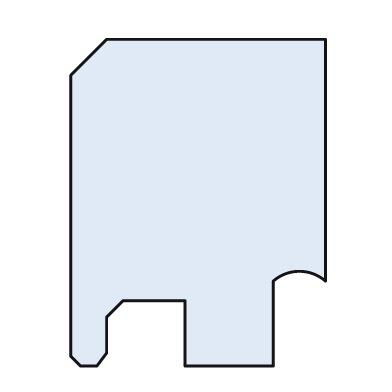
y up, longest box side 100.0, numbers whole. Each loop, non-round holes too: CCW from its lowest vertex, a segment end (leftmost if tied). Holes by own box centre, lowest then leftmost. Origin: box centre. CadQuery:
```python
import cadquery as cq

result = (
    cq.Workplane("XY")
    .moveTo(-36.0, -50.0)
    .lineTo(-31.0, -50.0)
    .lineTo(-28.0, -46.0)
    .lineTo(-28.0, -35.0)
    .lineTo(-23.0, -30.0)
    .lineTo(-4.0, -30.0)
    .lineTo(-4.0, -50.0)
    .lineTo(23.0, -50.0)
    .lineTo(23.0, -24.0)
    .threePointArc((31.0, -21.0), (39.0, -24.0))
    .lineTo(39.0, 50.0)
    .lineTo(-28.0, 50.0)
    .lineTo(-39.0, 39.0)
    .lineTo(-39.0, -47.0)
    .close()
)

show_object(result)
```